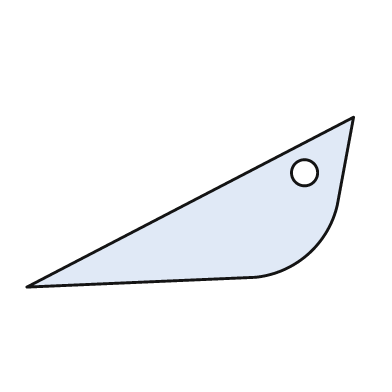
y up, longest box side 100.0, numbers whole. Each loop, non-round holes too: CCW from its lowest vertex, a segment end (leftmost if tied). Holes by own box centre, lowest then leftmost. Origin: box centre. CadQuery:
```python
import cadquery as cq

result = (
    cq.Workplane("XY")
    .moveTo(-50.0, -26.0)
    .lineTo(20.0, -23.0)
    .threePointArc((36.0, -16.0), (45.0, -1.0))
    .lineTo(50.0, 26.0)
    .close()
    .moveTo(35.0, 9.0)
    .circle(4.0)
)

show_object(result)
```